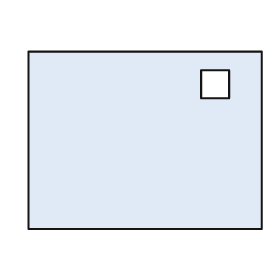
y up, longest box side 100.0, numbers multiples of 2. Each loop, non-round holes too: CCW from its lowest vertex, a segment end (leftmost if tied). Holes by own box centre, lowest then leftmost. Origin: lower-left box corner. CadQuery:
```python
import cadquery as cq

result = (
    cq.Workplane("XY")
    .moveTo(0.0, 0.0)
    .lineTo(100.0, 0.0)
    .lineTo(100.0, 76.0)
    .lineTo(0.0, 76.0)
    .close()
    .moveTo(74.0, 56.0)
    .lineTo(86.0, 56.0)
    .lineTo(86.0, 68.0)
    .lineTo(74.0, 68.0)
    .close()
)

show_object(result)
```